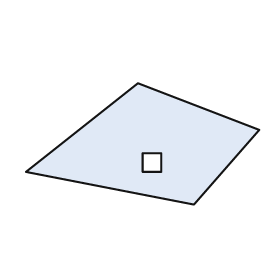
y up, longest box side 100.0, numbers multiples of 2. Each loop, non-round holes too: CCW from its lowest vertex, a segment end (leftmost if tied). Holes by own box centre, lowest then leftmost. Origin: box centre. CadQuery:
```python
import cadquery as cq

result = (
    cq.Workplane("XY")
    .moveTo(22.0, -26.0)
    .lineTo(50.0, 6.0)
    .lineTo(-2.0, 26.0)
    .lineTo(-50.0, -12.0)
    .close()
    .moveTo(0.0, -12.0)
    .lineTo(8.0, -12.0)
    .lineTo(8.0, -4.0)
    .lineTo(0.0, -4.0)
    .close()
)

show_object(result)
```